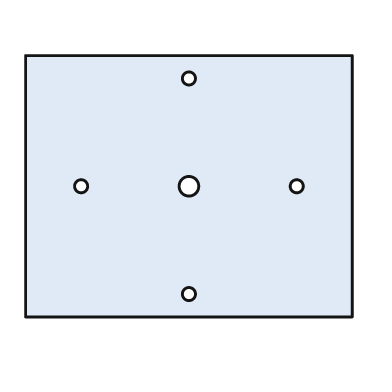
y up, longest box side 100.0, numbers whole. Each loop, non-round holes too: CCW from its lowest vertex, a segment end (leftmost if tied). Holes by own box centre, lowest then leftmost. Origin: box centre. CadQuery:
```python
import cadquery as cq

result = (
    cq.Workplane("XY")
    .moveTo(-50.0, -40.0)
    .lineTo(50.0, -40.0)
    .lineTo(50.0, 40.0)
    .lineTo(-50.0, 40.0)
    .close()
    .moveTo(0.0, -33.0)
    .circle(2.0)
    .moveTo(-33.0, 0.0)
    .circle(2.0)
    .moveTo(0.0, 0.0)
    .circle(3.0)
    .moveTo(33.0, 0.0)
    .circle(2.0)
    .moveTo(0.0, 33.0)
    .circle(2.0)
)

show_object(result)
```